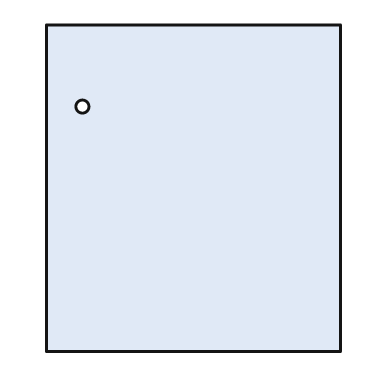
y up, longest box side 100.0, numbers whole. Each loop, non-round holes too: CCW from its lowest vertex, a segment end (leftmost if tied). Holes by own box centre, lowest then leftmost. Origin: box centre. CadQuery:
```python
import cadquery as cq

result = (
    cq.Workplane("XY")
    .moveTo(-45.0, -50.0)
    .lineTo(45.0, -50.0)
    .lineTo(45.0, 50.0)
    .lineTo(-45.0, 50.0)
    .close()
    .moveTo(-34.0, 25.0)
    .circle(2.0)
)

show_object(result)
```